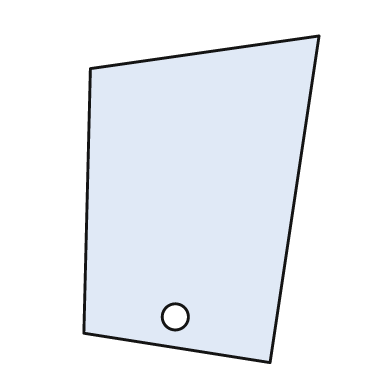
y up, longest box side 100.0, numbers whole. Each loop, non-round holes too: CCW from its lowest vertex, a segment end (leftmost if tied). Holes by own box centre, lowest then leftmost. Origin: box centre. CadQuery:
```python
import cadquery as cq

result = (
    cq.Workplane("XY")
    .moveTo(21.0, -50.0)
    .lineTo(36.0, 50.0)
    .lineTo(-34.0, 40.0)
    .lineTo(-36.0, -41.0)
    .close()
    .moveTo(-8.0, -36.0)
    .circle(4.0)
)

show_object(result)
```